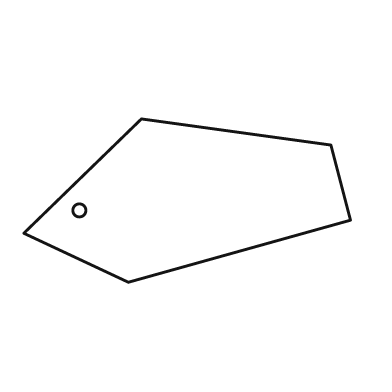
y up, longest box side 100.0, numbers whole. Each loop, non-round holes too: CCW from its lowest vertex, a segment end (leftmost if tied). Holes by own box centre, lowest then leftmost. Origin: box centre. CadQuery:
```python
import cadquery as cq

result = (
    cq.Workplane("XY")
    .moveTo(-18.0, -25.0)
    .lineTo(50.0, -6.0)
    .lineTo(44.0, 17.0)
    .lineTo(-14.0, 25.0)
    .lineTo(-50.0, -10.0)
    .close()
    .moveTo(-33.0, -3.0)
    .circle(2.0)
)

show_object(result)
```